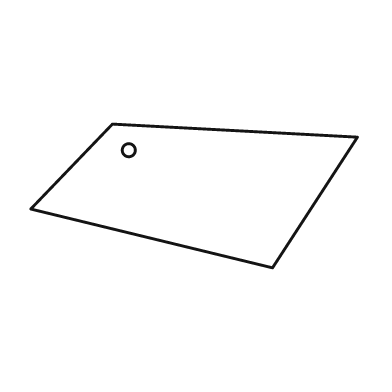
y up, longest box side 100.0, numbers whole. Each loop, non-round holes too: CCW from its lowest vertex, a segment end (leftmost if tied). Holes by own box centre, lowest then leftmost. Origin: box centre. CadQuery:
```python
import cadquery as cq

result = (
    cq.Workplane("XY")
    .moveTo(24.0, -22.0)
    .lineTo(50.0, 18.0)
    .lineTo(-25.0, 22.0)
    .lineTo(-50.0, -4.0)
    .close()
    .moveTo(-20.0, 14.0)
    .circle(2.0)
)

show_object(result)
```